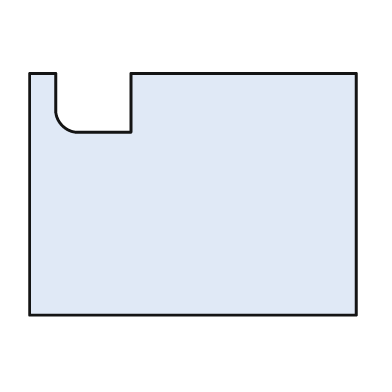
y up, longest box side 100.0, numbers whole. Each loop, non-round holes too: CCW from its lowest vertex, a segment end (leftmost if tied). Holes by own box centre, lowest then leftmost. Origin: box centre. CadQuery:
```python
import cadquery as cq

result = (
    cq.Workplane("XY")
    .moveTo(-50.0, -37.0)
    .lineTo(50.0, -37.0)
    .lineTo(50.0, 37.0)
    .lineTo(-19.0, 37.0)
    .lineTo(-19.0, 19.0)
    .lineTo(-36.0, 19.0)
    .threePointArc((-40.0, 21.0), (-42.0, 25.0))
    .lineTo(-42.0, 37.0)
    .lineTo(-50.0, 37.0)
    .close()
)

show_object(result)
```